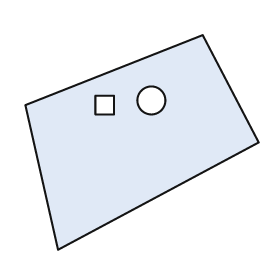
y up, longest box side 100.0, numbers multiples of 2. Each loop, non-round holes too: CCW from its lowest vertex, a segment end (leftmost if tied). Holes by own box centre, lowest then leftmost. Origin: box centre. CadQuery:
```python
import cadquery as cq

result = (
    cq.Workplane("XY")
    .moveTo(-36.0, -46.0)
    .lineTo(50.0, 0.0)
    .lineTo(26.0, 46.0)
    .lineTo(-50.0, 16.0)
    .close()
    .moveTo(-20.0, 12.0)
    .lineTo(-12.0, 12.0)
    .lineTo(-12.0, 20.0)
    .lineTo(-20.0, 20.0)
    .close()
    .moveTo(4.0, 18.0)
    .circle(6.0)
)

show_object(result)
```